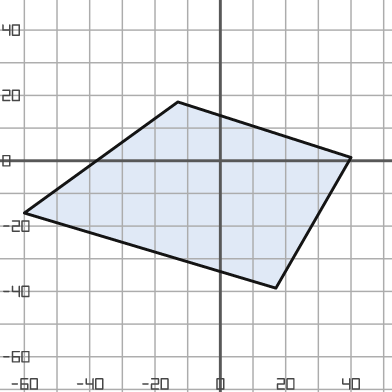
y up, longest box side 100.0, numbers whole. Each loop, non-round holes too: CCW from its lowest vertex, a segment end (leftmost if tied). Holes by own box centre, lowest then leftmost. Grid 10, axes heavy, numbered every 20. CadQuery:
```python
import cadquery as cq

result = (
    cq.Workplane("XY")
    .moveTo(17.0, -39.0)
    .lineTo(40.0, 1.0)
    .lineTo(-13.0, 18.0)
    .lineTo(-60.0, -16.0)
    .close()
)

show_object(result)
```